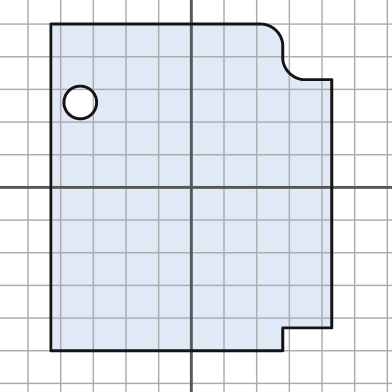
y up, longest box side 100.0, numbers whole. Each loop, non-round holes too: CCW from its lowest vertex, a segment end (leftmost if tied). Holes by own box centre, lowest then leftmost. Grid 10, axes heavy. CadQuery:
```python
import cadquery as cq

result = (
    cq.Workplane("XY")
    .moveTo(-43.0, -50.0)
    .lineTo(28.0, -50.0)
    .lineTo(28.0, -43.0)
    .lineTo(43.0, -43.0)
    .lineTo(43.0, 33.0)
    .lineTo(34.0, 33.0)
    .threePointArc((30.0, 35.0), (28.0, 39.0))
    .lineTo(28.0, 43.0)
    .threePointArc((26.0, 48.0), (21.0, 50.0))
    .lineTo(-43.0, 50.0)
    .close()
    .moveTo(-34.0, 26.0)
    .circle(5.0)
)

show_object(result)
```